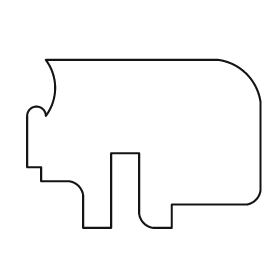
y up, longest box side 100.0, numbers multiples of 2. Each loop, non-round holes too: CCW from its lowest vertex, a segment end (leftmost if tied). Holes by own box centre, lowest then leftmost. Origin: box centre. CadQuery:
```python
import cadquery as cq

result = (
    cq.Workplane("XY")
    .moveTo(-26.0, -36.0)
    .lineTo(-14.0, -36.0)
    .lineTo(-14.0, -4.0)
    .lineTo(-2.0, -4.0)
    .lineTo(-2.0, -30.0)
    .threePointArc((0.0, -34.0), (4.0, -36.0))
    .lineTo(12.0, -36.0)
    .lineTo(12.0, -26.0)
    .lineTo(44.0, -26.0)
    .threePointArc((48.0, -24.0), (50.0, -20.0))
    .lineTo(50.0, 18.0)
    .threePointArc((44.0, 30.0), (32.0, 36.0))
    .lineTo(-42.0, 36.0)
    .threePointArc((-38.0, 24.0), (-42.0, 12.0))
    .threePointArc((-46.0, 16.0), (-50.0, 12.0))
    .lineTo(-50.0, -10.0)
    .lineTo(-44.0, -10.0)
    .lineTo(-44.0, -16.0)
    .lineTo(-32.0, -16.0)
    .threePointArc((-28.0, -18.0), (-26.0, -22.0))
    .close()
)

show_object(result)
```